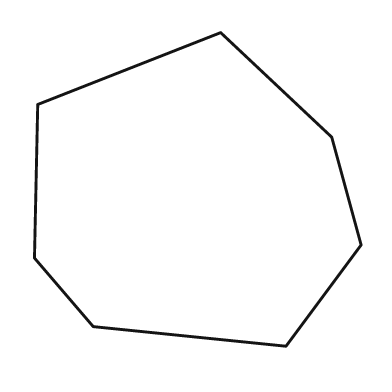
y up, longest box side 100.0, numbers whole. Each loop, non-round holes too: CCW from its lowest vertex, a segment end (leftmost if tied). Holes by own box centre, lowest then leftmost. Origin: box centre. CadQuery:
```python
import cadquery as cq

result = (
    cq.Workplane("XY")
    .moveTo(27.0, -48.0)
    .lineTo(50.0, -17.0)
    .lineTo(41.0, 16.0)
    .lineTo(7.0, 48.0)
    .lineTo(-49.0, 26.0)
    .lineTo(-50.0, -21.0)
    .lineTo(-32.0, -42.0)
    .close()
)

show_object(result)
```